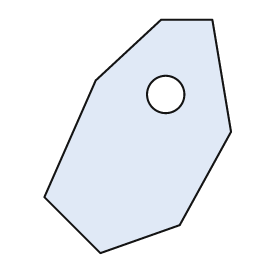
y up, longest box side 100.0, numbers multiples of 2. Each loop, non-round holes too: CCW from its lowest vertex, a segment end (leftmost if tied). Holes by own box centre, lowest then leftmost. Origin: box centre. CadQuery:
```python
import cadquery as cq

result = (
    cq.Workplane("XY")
    .moveTo(-16.0, -50.0)
    .lineTo(18.0, -38.0)
    .lineTo(40.0, 2.0)
    .lineTo(32.0, 50.0)
    .lineTo(10.0, 50.0)
    .lineTo(-18.0, 24.0)
    .lineTo(-40.0, -26.0)
    .close()
    .moveTo(12.0, 18.0)
    .circle(8.0)
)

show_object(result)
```